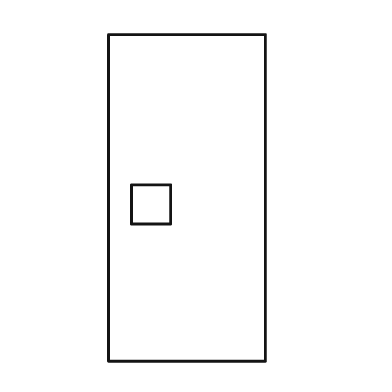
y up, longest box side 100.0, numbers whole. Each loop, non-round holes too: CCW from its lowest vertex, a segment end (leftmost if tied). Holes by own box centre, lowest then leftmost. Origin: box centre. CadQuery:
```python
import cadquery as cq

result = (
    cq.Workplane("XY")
    .moveTo(-24.0, -50.0)
    .lineTo(24.0, -50.0)
    .lineTo(24.0, 50.0)
    .lineTo(-24.0, 50.0)
    .close()
    .moveTo(-17.0, -8.0)
    .lineTo(-5.0, -8.0)
    .lineTo(-5.0, 4.0)
    .lineTo(-17.0, 4.0)
    .close()
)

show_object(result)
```